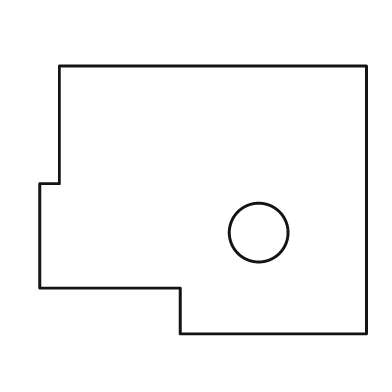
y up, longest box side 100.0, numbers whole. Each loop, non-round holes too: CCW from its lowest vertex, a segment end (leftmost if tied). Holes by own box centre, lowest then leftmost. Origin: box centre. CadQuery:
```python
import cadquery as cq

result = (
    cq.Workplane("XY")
    .moveTo(-7.0, -41.0)
    .lineTo(50.0, -41.0)
    .lineTo(50.0, 41.0)
    .lineTo(-44.0, 41.0)
    .lineTo(-44.0, 5.0)
    .lineTo(-50.0, 5.0)
    .lineTo(-50.0, -27.0)
    .lineTo(-7.0, -27.0)
    .close()
    .moveTo(17.0, -10.0)
    .circle(9.0)
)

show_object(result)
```